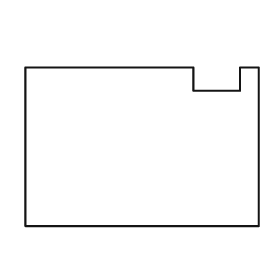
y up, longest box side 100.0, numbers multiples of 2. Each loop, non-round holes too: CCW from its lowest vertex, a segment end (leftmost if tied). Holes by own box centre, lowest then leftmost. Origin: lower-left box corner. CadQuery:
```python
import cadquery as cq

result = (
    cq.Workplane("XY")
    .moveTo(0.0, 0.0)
    .lineTo(100.0, 0.0)
    .lineTo(100.0, 68.0)
    .lineTo(92.0, 68.0)
    .lineTo(92.0, 58.0)
    .lineTo(72.0, 58.0)
    .lineTo(72.0, 68.0)
    .lineTo(0.0, 68.0)
    .close()
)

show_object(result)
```